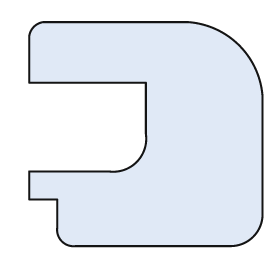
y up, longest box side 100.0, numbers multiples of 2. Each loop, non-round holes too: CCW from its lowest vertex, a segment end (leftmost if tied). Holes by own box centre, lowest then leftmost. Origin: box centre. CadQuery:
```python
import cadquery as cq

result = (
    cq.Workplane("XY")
    .moveTo(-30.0, -48.0)
    .lineTo(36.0, -48.0)
    .threePointArc((46.0, -44.0), (50.0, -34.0))
    .lineTo(50.0, 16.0)
    .threePointArc((40.0, 38.0), (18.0, 48.0))
    .lineTo(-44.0, 48.0)
    .threePointArc((-48.0, 46.0), (-50.0, 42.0))
    .lineTo(-50.0, 22.0)
    .lineTo(0.0, 22.0)
    .lineTo(0.0, 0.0)
    .threePointArc((-4.0, -12.0), (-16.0, -16.0))
    .lineTo(-50.0, -16.0)
    .lineTo(-50.0, -28.0)
    .lineTo(-38.0, -28.0)
    .lineTo(-38.0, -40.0)
    .threePointArc((-36.0, -46.0), (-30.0, -48.0))
    .close()
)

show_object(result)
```